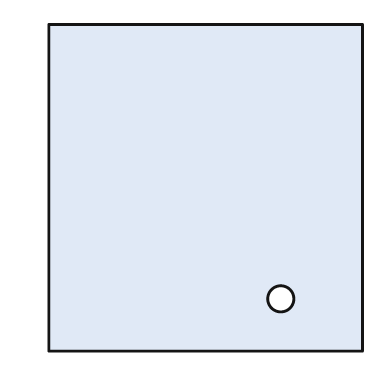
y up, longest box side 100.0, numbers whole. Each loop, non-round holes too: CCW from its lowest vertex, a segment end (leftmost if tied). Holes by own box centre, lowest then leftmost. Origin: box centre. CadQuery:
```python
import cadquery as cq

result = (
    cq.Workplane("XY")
    .moveTo(-48.0, -50.0)
    .lineTo(48.0, -50.0)
    .lineTo(48.0, 50.0)
    .lineTo(-48.0, 50.0)
    .close()
    .moveTo(23.0, -34.0)
    .circle(4.0)
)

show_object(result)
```